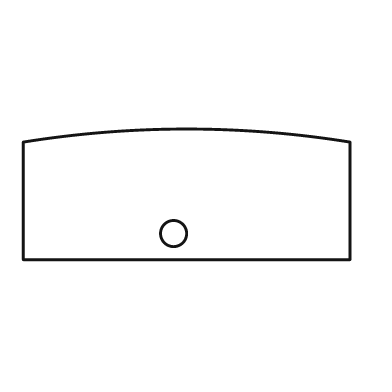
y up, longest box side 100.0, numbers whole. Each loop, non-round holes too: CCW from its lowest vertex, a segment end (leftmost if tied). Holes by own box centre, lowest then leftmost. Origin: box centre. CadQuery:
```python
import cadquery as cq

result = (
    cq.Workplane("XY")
    .moveTo(-50.0, -20.0)
    .lineTo(50.0, -20.0)
    .lineTo(50.0, 16.0)
    .threePointArc((0.0, 20.0), (-50.0, 16.0))
    .close()
    .moveTo(-4.0, -12.0)
    .circle(4.0)
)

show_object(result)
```